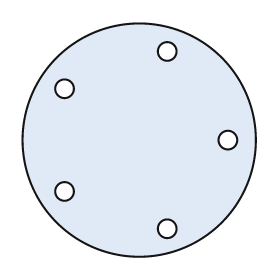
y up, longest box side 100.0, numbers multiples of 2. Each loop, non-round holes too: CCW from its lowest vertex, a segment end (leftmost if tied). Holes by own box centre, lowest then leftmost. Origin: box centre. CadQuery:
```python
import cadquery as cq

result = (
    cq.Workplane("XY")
    .moveTo(0.0, 0.0)
    .circle(50.0)
    .moveTo(12.0, -38.0)
    .circle(4.0)
    .moveTo(-32.0, -22.0)
    .circle(4.0)
    .moveTo(38.0, 0.0)
    .circle(4.0)
    .moveTo(-32.0, 22.0)
    .circle(4.0)
    .moveTo(12.0, 38.0)
    .circle(4.0)
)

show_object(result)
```